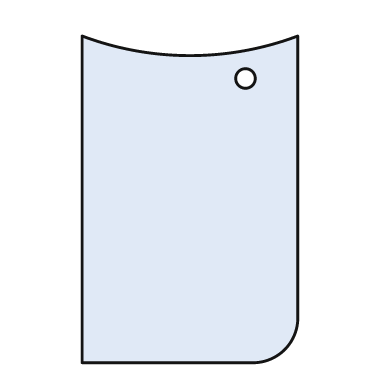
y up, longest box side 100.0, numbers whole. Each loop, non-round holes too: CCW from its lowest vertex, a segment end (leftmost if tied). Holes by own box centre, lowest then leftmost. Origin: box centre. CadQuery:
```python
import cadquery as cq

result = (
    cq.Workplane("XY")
    .moveTo(-33.0, -50.0)
    .lineTo(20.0, -50.0)
    .threePointArc((29.0, -46.0), (33.0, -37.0))
    .lineTo(33.0, 50.0)
    .threePointArc((0.0, 44.0), (-33.0, 50.0))
    .close()
    .moveTo(17.0, 37.0)
    .circle(3.0)
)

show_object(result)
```